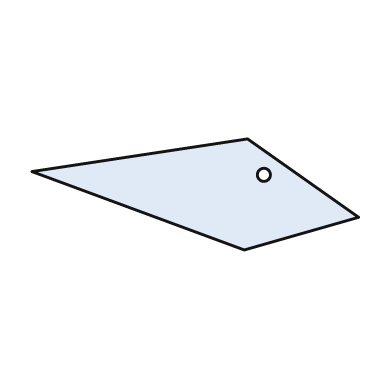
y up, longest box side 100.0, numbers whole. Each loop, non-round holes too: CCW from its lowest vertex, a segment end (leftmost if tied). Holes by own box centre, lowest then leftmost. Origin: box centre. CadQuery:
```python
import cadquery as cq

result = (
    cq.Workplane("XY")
    .moveTo(15.0, -17.0)
    .lineTo(50.0, -7.0)
    .lineTo(16.0, 17.0)
    .lineTo(-50.0, 7.0)
    .close()
    .moveTo(21.0, 6.0)
    .circle(2.0)
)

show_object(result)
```